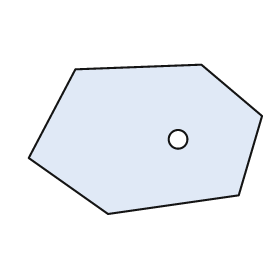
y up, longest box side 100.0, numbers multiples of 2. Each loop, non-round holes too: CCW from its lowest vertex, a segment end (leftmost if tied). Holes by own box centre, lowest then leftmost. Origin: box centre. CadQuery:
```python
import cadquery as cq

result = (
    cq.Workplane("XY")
    .moveTo(-16.0, -32.0)
    .lineTo(40.0, -24.0)
    .lineTo(50.0, 10.0)
    .lineTo(24.0, 32.0)
    .lineTo(-30.0, 30.0)
    .lineTo(-50.0, -8.0)
    .close()
    .moveTo(14.0, 0.0)
    .circle(4.0)
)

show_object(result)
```